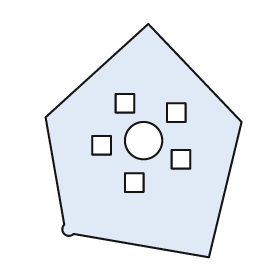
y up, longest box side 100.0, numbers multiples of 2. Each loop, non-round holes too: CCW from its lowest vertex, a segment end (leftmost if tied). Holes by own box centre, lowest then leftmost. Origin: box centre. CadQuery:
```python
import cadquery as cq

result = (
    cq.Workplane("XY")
    .moveTo(28.0, -50.0)
    .lineTo(42.0, 8.0)
    .lineTo(2.0, 50.0)
    .lineTo(-42.0, 10.0)
    .lineTo(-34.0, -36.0)
    .threePointArc((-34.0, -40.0), (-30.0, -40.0))
    .close()
    .moveTo(-8.0, -22.0)
    .lineTo(0.0, -22.0)
    .lineTo(0.0, -14.0)
    .lineTo(-8.0, -14.0)
    .close()
    .moveTo(12.0, -12.0)
    .lineTo(20.0, -12.0)
    .lineTo(20.0, -4.0)
    .lineTo(12.0, -4.0)
    .close()
    .moveTo(-22.0, -6.0)
    .lineTo(-14.0, -6.0)
    .lineTo(-14.0, 2.0)
    .lineTo(-22.0, 2.0)
    .close()
    .moveTo(0.0, 0.0)
    .circle(8.0)
    .moveTo(10.0, 8.0)
    .lineTo(18.0, 8.0)
    .lineTo(18.0, 16.0)
    .lineTo(10.0, 16.0)
    .close()
    .moveTo(-12.0, 12.0)
    .lineTo(-4.0, 12.0)
    .lineTo(-4.0, 20.0)
    .lineTo(-12.0, 20.0)
    .close()
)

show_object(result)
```